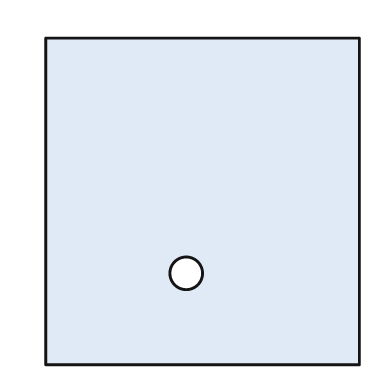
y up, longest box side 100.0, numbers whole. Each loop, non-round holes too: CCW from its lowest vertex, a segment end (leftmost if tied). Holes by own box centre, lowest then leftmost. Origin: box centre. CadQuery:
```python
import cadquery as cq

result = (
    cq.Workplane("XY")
    .moveTo(-48.0, -50.0)
    .lineTo(48.0, -50.0)
    .lineTo(48.0, 50.0)
    .lineTo(-48.0, 50.0)
    .close()
    .moveTo(-5.0, -22.0)
    .circle(5.0)
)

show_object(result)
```